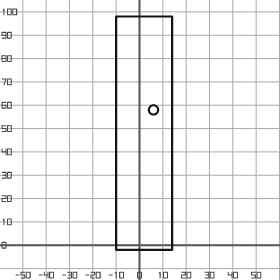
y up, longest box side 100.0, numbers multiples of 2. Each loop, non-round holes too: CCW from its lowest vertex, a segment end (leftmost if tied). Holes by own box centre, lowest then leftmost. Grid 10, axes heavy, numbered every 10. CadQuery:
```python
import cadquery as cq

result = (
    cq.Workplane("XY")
    .moveTo(-10.0, -2.0)
    .lineTo(14.0, -2.0)
    .lineTo(14.0, 98.0)
    .lineTo(-10.0, 98.0)
    .close()
    .moveTo(6.0, 58.0)
    .circle(2.0)
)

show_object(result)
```